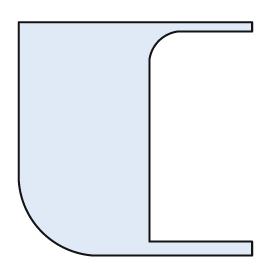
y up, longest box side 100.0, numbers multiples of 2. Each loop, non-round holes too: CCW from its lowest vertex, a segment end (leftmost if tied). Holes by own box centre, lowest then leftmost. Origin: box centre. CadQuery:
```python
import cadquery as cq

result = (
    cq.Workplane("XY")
    .moveTo(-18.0, -50.0)
    .lineTo(50.0, -50.0)
    .lineTo(50.0, -44.0)
    .lineTo(6.0, -44.0)
    .lineTo(6.0, 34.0)
    .threePointArc((10.0, 42.0), (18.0, 46.0))
    .lineTo(50.0, 46.0)
    .lineTo(50.0, 50.0)
    .lineTo(-50.0, 50.0)
    .lineTo(-50.0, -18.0)
    .threePointArc((-40.0, -40.0), (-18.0, -50.0))
    .close()
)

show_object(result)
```